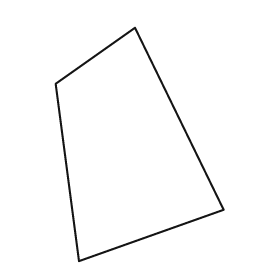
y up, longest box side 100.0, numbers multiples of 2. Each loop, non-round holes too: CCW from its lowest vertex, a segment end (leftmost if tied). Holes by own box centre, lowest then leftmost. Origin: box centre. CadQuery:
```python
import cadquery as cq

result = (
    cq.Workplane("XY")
    .moveTo(-26.0, -50.0)
    .lineTo(36.0, -28.0)
    .lineTo(-2.0, 50.0)
    .lineTo(-36.0, 26.0)
    .close()
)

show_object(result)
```